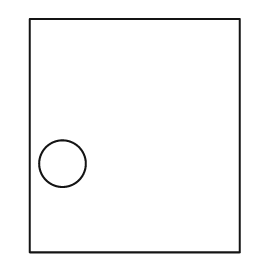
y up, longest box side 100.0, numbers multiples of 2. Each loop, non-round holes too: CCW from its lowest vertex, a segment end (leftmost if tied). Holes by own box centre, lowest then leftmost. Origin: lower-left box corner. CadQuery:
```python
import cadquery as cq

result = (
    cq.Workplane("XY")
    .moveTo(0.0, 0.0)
    .lineTo(90.0, 0.0)
    .lineTo(90.0, 100.0)
    .lineTo(0.0, 100.0)
    .close()
    .moveTo(14.0, 38.0)
    .circle(10.0)
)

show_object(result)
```